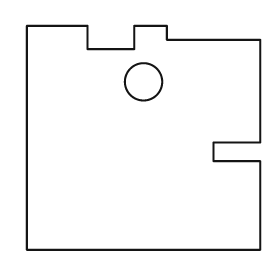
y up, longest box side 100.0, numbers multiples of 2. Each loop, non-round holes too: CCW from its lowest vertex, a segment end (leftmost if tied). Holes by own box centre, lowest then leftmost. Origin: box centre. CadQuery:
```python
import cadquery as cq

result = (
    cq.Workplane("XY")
    .moveTo(-50.0, -48.0)
    .lineTo(50.0, -48.0)
    .lineTo(50.0, -10.0)
    .lineTo(30.0, -10.0)
    .lineTo(30.0, -2.0)
    .lineTo(50.0, -2.0)
    .lineTo(50.0, 42.0)
    .lineTo(10.0, 42.0)
    .lineTo(10.0, 48.0)
    .lineTo(-4.0, 48.0)
    .lineTo(-4.0, 38.0)
    .lineTo(-24.0, 38.0)
    .lineTo(-24.0, 48.0)
    .lineTo(-50.0, 48.0)
    .close()
    .moveTo(0.0, 24.0)
    .circle(8.0)
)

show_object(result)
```